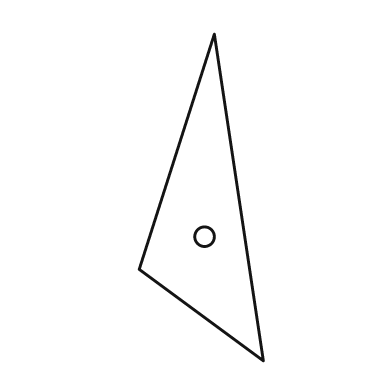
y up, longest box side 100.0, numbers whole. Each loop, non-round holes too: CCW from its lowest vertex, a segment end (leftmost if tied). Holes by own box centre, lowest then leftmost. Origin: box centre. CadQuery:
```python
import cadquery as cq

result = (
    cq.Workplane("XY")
    .moveTo(19.0, -50.0)
    .lineTo(4.0, 50.0)
    .lineTo(-19.0, -22.0)
    .close()
    .moveTo(1.0, -12.0)
    .circle(3.0)
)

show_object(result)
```